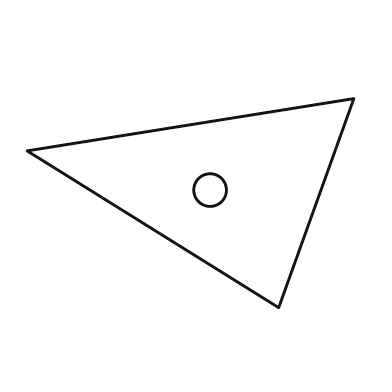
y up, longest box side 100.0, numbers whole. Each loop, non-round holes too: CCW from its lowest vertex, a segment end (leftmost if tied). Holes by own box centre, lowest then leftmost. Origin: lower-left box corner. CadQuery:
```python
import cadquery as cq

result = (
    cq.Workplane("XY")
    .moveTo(77.0, 0.0)
    .lineTo(100.0, 64.0)
    .lineTo(0.0, 48.0)
    .close()
    .moveTo(56.0, 36.0)
    .circle(5.0)
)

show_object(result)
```